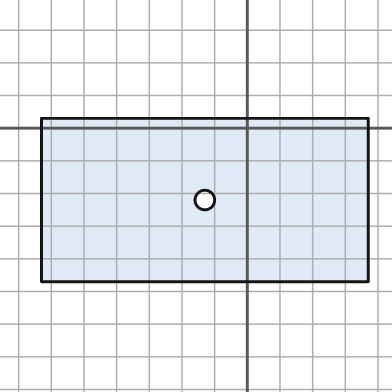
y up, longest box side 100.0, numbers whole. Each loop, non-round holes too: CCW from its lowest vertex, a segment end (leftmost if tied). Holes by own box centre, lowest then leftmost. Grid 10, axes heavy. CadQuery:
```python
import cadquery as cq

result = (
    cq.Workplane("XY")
    .moveTo(-63.0, -47.0)
    .lineTo(37.0, -47.0)
    .lineTo(37.0, 3.0)
    .lineTo(-63.0, 3.0)
    .close()
    .moveTo(-13.0, -22.0)
    .circle(3.0)
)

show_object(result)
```